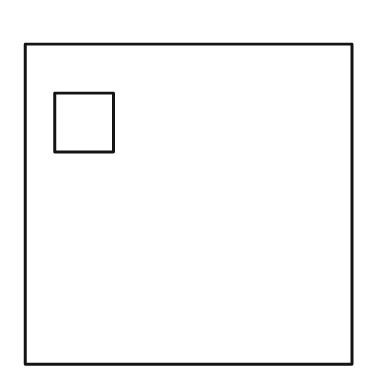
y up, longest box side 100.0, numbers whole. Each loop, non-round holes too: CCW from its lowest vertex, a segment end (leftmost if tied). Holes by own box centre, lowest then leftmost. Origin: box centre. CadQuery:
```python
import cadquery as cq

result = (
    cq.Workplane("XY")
    .moveTo(-50.0, -49.0)
    .lineTo(50.0, -49.0)
    .lineTo(50.0, 49.0)
    .lineTo(-50.0, 49.0)
    .close()
    .moveTo(-41.0, 16.0)
    .lineTo(-23.0, 16.0)
    .lineTo(-23.0, 34.0)
    .lineTo(-41.0, 34.0)
    .close()
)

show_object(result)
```